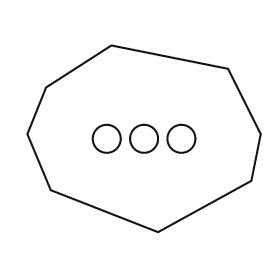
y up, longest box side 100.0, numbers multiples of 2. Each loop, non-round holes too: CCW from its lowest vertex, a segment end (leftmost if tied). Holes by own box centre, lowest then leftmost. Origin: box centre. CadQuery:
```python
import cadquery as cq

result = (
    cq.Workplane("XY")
    .moveTo(6.0, -40.0)
    .lineTo(46.0, -18.0)
    .lineTo(50.0, 2.0)
    .lineTo(36.0, 30.0)
    .lineTo(-14.0, 40.0)
    .lineTo(-42.0, 22.0)
    .lineTo(-50.0, 2.0)
    .lineTo(-40.0, -22.0)
    .close()
    .moveTo(-16.0, 0.0)
    .circle(6.0)
    .moveTo(0.0, 0.0)
    .circle(6.0)
    .moveTo(16.0, 0.0)
    .circle(6.0)
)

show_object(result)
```